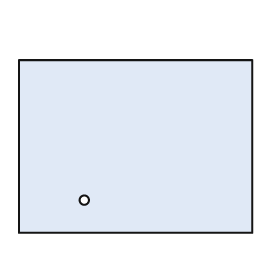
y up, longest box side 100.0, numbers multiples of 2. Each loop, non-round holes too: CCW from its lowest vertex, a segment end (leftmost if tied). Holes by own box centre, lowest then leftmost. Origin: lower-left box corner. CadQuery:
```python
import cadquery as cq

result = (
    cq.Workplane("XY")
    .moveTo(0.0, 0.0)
    .lineTo(100.0, 0.0)
    .lineTo(100.0, 74.0)
    .lineTo(0.0, 74.0)
    .close()
    .moveTo(28.0, 14.0)
    .circle(2.0)
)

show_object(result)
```